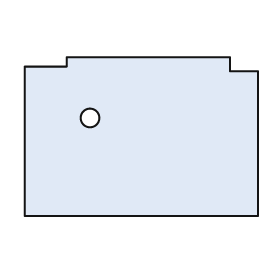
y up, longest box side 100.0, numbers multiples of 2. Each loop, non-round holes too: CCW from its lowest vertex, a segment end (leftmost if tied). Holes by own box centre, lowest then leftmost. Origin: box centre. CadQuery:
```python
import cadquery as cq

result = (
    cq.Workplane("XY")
    .moveTo(-50.0, -34.0)
    .lineTo(50.0, -34.0)
    .lineTo(50.0, 28.0)
    .lineTo(38.0, 28.0)
    .lineTo(38.0, 34.0)
    .lineTo(-32.0, 34.0)
    .lineTo(-32.0, 30.0)
    .lineTo(-50.0, 30.0)
    .close()
    .moveTo(-22.0, 8.0)
    .circle(4.0)
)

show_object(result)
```